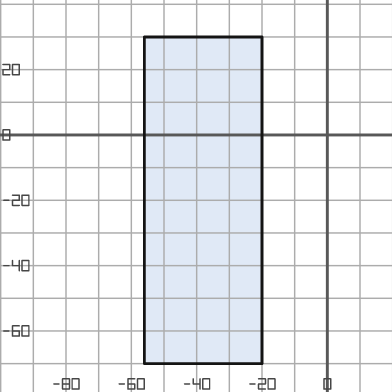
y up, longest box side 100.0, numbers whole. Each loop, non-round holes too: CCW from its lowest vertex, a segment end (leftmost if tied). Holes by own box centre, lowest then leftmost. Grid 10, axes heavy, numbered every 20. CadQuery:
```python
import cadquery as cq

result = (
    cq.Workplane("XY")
    .moveTo(-56.0, -70.0)
    .lineTo(-20.0, -70.0)
    .lineTo(-20.0, 30.0)
    .lineTo(-56.0, 30.0)
    .close()
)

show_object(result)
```